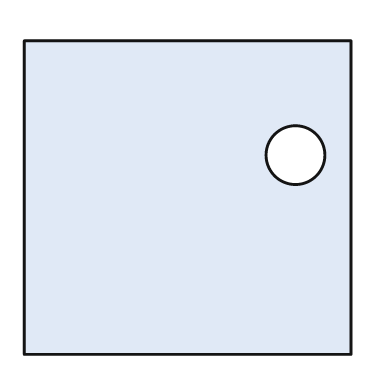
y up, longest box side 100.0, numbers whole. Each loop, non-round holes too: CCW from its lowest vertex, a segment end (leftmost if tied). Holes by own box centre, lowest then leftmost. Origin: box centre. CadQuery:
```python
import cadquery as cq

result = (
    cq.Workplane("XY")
    .moveTo(-50.0, -48.0)
    .lineTo(50.0, -48.0)
    .lineTo(50.0, 48.0)
    .lineTo(-50.0, 48.0)
    .close()
    .moveTo(33.0, 13.0)
    .circle(9.0)
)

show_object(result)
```